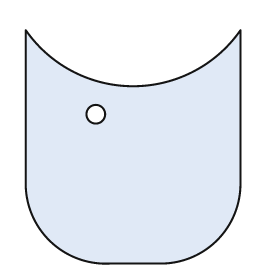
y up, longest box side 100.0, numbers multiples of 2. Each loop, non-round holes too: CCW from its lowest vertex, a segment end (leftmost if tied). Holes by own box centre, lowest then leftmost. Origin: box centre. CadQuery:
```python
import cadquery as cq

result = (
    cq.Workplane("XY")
    .moveTo(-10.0, -50.0)
    .lineTo(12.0, -50.0)
    .threePointArc((36.0, -40.0), (46.0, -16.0))
    .lineTo(46.0, 50.0)
    .threePointArc((0.0, 26.0), (-46.0, 50.0))
    .lineTo(-46.0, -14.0)
    .threePointArc((-36.0, -40.0), (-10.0, -50.0))
    .close()
    .moveTo(-16.0, 14.0)
    .circle(4.0)
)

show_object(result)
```